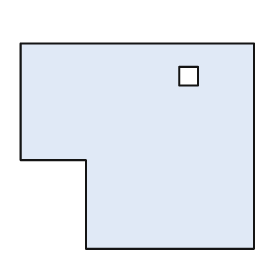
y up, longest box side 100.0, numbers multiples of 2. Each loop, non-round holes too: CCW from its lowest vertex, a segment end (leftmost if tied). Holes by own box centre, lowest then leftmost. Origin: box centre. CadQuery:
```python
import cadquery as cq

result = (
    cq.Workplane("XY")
    .moveTo(-22.0, -44.0)
    .lineTo(50.0, -44.0)
    .lineTo(50.0, 44.0)
    .lineTo(-50.0, 44.0)
    .lineTo(-50.0, -6.0)
    .lineTo(-22.0, -6.0)
    .close()
    .moveTo(18.0, 26.0)
    .lineTo(26.0, 26.0)
    .lineTo(26.0, 34.0)
    .lineTo(18.0, 34.0)
    .close()
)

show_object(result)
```